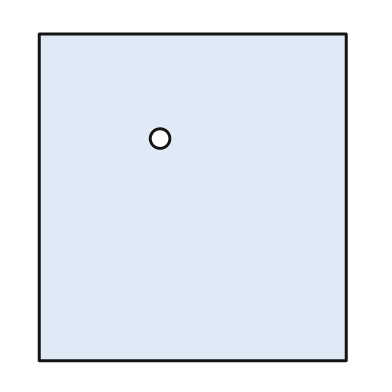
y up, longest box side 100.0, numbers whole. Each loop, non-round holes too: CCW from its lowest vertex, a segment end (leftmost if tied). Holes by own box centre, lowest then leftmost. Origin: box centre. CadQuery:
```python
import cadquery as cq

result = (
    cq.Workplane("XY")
    .moveTo(-47.0, -50.0)
    .lineTo(47.0, -50.0)
    .lineTo(47.0, 50.0)
    .lineTo(-47.0, 50.0)
    .close()
    .moveTo(-10.0, 18.0)
    .circle(3.0)
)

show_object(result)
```